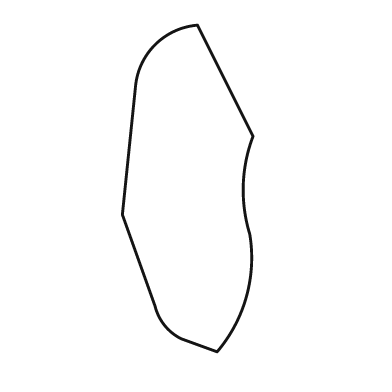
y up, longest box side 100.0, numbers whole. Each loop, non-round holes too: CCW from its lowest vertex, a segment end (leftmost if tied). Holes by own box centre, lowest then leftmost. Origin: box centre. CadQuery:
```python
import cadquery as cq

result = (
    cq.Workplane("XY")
    .moveTo(9.0, -50.0)
    .threePointArc((18.0, -33.0), (19.0, -14.0))
    .threePointArc((17.0, 1.0), (20.0, 16.0))
    .lineTo(3.0, 50.0)
    .threePointArc((-10.0, 44.0), (-16.0, 31.0))
    .lineTo(-20.0, -8.0)
    .lineTo(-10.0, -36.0)
    .threePointArc((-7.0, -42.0), (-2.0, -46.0))
    .close()
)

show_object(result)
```